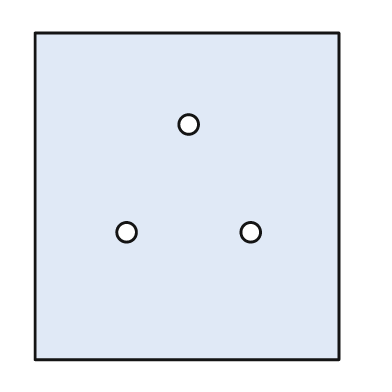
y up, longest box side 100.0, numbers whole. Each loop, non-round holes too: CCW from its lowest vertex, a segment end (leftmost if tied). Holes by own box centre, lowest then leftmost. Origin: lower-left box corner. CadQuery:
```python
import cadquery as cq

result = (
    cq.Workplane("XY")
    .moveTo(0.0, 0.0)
    .lineTo(93.0, 0.0)
    .lineTo(93.0, 100.0)
    .lineTo(0.0, 100.0)
    .close()
    .moveTo(28.0, 39.0)
    .circle(3.0)
    .moveTo(66.0, 39.0)
    .circle(3.0)
    .moveTo(47.0, 72.0)
    .circle(3.0)
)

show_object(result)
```